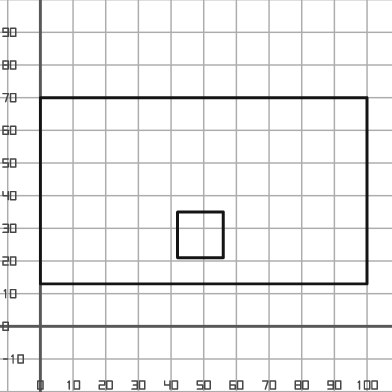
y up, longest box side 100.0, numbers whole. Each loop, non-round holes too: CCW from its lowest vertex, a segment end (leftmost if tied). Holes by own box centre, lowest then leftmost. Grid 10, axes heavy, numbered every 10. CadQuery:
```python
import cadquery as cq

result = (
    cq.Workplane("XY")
    .moveTo(0.0, 13.0)
    .lineTo(100.0, 13.0)
    .lineTo(100.0, 70.0)
    .lineTo(0.0, 70.0)
    .close()
    .moveTo(42.0, 21.0)
    .lineTo(56.0, 21.0)
    .lineTo(56.0, 35.0)
    .lineTo(42.0, 35.0)
    .close()
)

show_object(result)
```